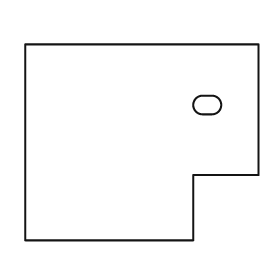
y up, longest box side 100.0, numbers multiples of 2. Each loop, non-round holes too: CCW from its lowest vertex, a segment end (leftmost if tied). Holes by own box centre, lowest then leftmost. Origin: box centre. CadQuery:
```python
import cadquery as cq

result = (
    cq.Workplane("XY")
    .moveTo(-50.0, -42.0)
    .lineTo(22.0, -42.0)
    .lineTo(22.0, -14.0)
    .lineTo(50.0, -14.0)
    .lineTo(50.0, 42.0)
    .lineTo(-50.0, 42.0)
    .close()
    .moveTo(26.0, 12.0)
    .lineTo(30.0, 12.0)
    .threePointArc((34.0, 16.0), (30.0, 20.0))
    .lineTo(26.0, 20.0)
    .threePointArc((22.0, 16.0), (26.0, 12.0))
    .close()
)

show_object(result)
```